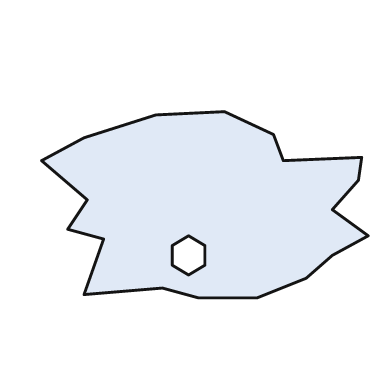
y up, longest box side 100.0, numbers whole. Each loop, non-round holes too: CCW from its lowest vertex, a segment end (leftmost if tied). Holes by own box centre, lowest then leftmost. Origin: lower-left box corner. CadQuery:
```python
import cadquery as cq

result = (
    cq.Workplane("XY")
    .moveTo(48.0, 0.0)
    .lineTo(66.0, 0.0)
    .lineTo(81.0, 6.0)
    .lineTo(89.0, 13.0)
    .lineTo(100.0, 19.0)
    .lineTo(89.0, 27.0)
    .lineTo(97.0, 36.0)
    .lineTo(98.0, 43.0)
    .lineTo(74.0, 42.0)
    .lineTo(71.0, 50.0)
    .lineTo(56.0, 57.0)
    .lineTo(35.0, 56.0)
    .lineTo(13.0, 49.0)
    .lineTo(0.0, 42.0)
    .lineTo(14.0, 30.0)
    .lineTo(8.0, 21.0)
    .lineTo(19.0, 18.0)
    .lineTo(13.0, 1.0)
    .lineTo(37.0, 3.0)
    .close()
    .moveTo(45.0, 7.0)
    .lineTo(50.0, 10.0)
    .lineTo(50.0, 16.0)
    .lineTo(45.0, 19.0)
    .lineTo(40.0, 16.0)
    .lineTo(40.0, 10.0)
    .close()
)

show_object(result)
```